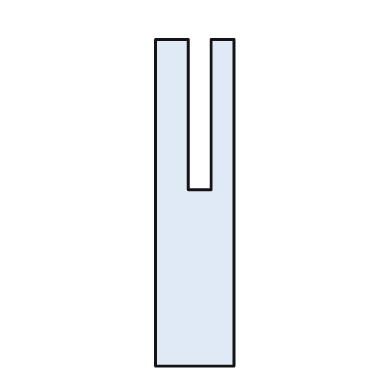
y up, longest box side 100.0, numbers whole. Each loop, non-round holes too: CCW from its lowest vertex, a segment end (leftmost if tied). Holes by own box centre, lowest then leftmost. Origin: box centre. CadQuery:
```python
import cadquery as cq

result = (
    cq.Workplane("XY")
    .moveTo(-12.0, -50.0)
    .lineTo(12.0, -50.0)
    .lineTo(12.0, 50.0)
    .lineTo(5.0, 50.0)
    .lineTo(5.0, 4.0)
    .lineTo(-2.0, 4.0)
    .lineTo(-2.0, 50.0)
    .lineTo(-12.0, 50.0)
    .close()
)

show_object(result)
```